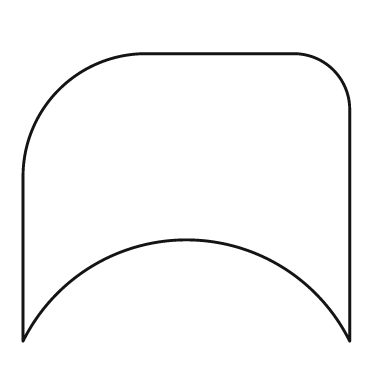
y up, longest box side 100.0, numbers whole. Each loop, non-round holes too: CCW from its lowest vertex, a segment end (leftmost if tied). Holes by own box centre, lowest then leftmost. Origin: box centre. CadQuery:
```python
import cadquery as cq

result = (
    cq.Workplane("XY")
    .moveTo(-50.0, -44.0)
    .threePointArc((0.0, -13.0), (50.0, -44.0))
    .lineTo(50.0, 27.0)
    .threePointArc((45.0, 39.0), (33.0, 44.0))
    .lineTo(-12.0, 44.0)
    .threePointArc((-39.0, 33.0), (-50.0, 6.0))
    .close()
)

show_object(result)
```